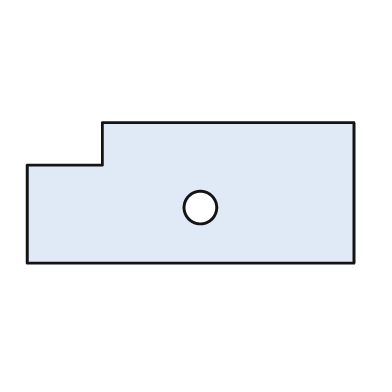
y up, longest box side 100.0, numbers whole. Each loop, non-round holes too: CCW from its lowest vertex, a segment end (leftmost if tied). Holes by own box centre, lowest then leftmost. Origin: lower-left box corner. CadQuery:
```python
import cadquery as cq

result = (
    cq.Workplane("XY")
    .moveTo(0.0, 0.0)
    .lineTo(100.0, 0.0)
    .lineTo(100.0, 43.0)
    .lineTo(23.0, 43.0)
    .lineTo(23.0, 30.0)
    .lineTo(0.0, 30.0)
    .close()
    .moveTo(53.0, 17.0)
    .circle(5.0)
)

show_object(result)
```